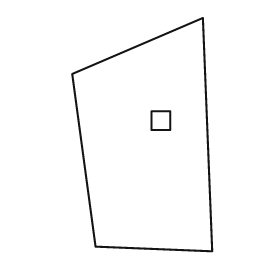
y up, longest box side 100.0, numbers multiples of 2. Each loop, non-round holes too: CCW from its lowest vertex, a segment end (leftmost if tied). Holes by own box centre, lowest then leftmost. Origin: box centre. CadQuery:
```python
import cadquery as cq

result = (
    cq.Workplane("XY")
    .moveTo(30.0, -50.0)
    .lineTo(26.0, 50.0)
    .lineTo(-30.0, 26.0)
    .lineTo(-20.0, -48.0)
    .close()
    .moveTo(4.0, 2.0)
    .lineTo(12.0, 2.0)
    .lineTo(12.0, 10.0)
    .lineTo(4.0, 10.0)
    .close()
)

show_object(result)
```